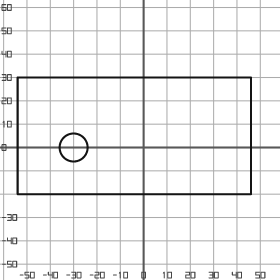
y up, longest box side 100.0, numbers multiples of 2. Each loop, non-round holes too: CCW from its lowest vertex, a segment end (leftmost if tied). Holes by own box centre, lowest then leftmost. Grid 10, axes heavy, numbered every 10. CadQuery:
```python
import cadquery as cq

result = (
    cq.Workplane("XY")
    .moveTo(-54.0, -20.0)
    .lineTo(46.0, -20.0)
    .lineTo(46.0, 30.0)
    .lineTo(-54.0, 30.0)
    .close()
    .moveTo(-30.0, 0.0)
    .circle(6.0)
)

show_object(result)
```